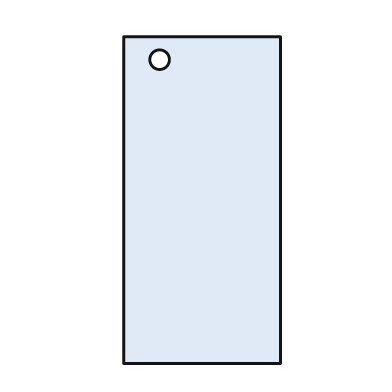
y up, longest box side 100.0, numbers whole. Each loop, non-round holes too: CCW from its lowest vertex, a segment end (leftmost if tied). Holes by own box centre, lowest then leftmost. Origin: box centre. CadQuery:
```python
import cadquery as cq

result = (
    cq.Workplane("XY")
    .moveTo(-24.0, -50.0)
    .lineTo(24.0, -50.0)
    .lineTo(24.0, 50.0)
    .lineTo(-24.0, 50.0)
    .close()
    .moveTo(-13.0, 43.0)
    .circle(3.0)
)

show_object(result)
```